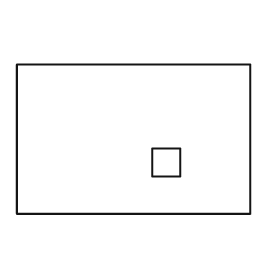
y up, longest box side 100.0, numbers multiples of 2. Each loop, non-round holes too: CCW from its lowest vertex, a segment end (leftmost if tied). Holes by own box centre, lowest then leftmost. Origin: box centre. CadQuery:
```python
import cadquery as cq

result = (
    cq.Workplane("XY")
    .moveTo(-50.0, -32.0)
    .lineTo(50.0, -32.0)
    .lineTo(50.0, 32.0)
    .lineTo(-50.0, 32.0)
    .close()
    .moveTo(8.0, -16.0)
    .lineTo(20.0, -16.0)
    .lineTo(20.0, -4.0)
    .lineTo(8.0, -4.0)
    .close()
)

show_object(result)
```